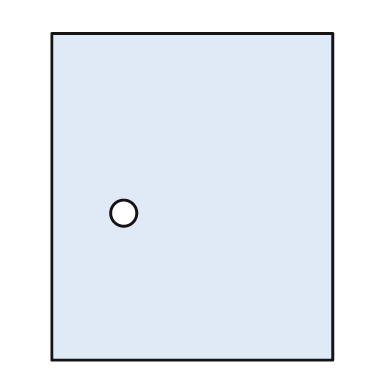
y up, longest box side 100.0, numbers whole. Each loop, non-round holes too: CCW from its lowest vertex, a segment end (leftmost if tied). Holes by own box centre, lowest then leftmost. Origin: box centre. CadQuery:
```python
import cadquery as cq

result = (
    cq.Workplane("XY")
    .moveTo(-43.0, -50.0)
    .lineTo(43.0, -50.0)
    .lineTo(43.0, 50.0)
    .lineTo(-43.0, 50.0)
    .close()
    .moveTo(-21.0, -5.0)
    .circle(4.0)
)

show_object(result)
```